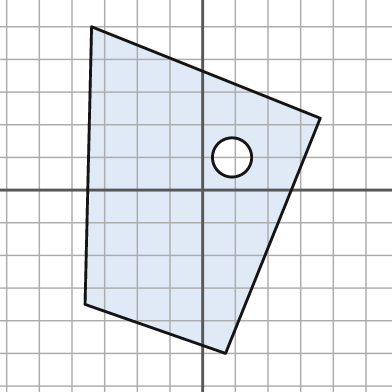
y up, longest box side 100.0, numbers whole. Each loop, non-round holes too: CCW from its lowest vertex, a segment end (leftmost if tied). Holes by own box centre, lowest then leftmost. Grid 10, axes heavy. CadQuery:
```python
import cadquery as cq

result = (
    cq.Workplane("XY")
    .moveTo(7.0, -50.0)
    .lineTo(36.0, 22.0)
    .lineTo(-34.0, 50.0)
    .lineTo(-36.0, -35.0)
    .close()
    .moveTo(9.0, 10.0)
    .circle(6.0)
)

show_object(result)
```